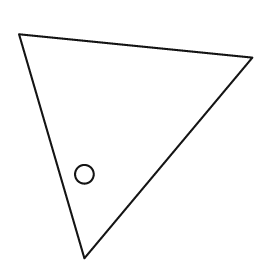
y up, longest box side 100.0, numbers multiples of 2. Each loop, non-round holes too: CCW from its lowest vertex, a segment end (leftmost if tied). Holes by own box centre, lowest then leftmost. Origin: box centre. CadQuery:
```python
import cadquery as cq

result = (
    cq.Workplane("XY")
    .moveTo(-22.0, -48.0)
    .lineTo(50.0, 38.0)
    .lineTo(-50.0, 48.0)
    .close()
    .moveTo(-22.0, -12.0)
    .circle(4.0)
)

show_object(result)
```